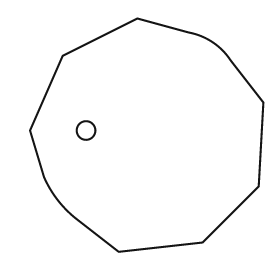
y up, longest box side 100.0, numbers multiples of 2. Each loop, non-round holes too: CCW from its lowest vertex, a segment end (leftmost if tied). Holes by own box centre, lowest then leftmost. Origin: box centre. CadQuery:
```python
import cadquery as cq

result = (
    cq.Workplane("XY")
    .moveTo(-12.0, -50.0)
    .lineTo(24.0, -46.0)
    .lineTo(48.0, -22.0)
    .lineTo(50.0, 14.0)
    .lineTo(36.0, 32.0)
    .threePointArc((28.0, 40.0), (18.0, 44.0))
    .lineTo(-4.0, 50.0)
    .lineTo(-36.0, 34.0)
    .lineTo(-50.0, 2.0)
    .lineTo(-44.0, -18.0)
    .threePointArc((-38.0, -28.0), (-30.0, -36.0))
    .close()
    .moveTo(-26.0, 2.0)
    .circle(4.0)
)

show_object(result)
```